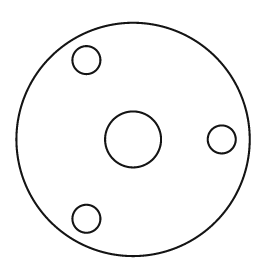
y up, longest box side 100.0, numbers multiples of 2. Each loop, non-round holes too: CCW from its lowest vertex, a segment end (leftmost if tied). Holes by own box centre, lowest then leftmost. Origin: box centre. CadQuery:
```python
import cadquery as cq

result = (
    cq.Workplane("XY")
    .moveTo(0.0, 0.0)
    .circle(50.0)
    .moveTo(-20.0, -34.0)
    .circle(6.0)
    .moveTo(0.0, 0.0)
    .circle(12.0)
    .moveTo(38.0, 0.0)
    .circle(6.0)
    .moveTo(-20.0, 34.0)
    .circle(6.0)
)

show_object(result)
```